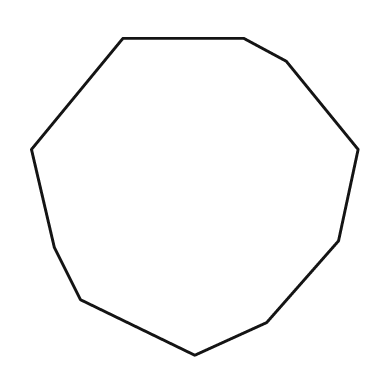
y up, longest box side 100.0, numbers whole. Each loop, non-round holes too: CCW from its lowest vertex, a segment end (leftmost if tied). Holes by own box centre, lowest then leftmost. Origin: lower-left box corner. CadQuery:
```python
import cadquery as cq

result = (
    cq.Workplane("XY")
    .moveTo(50.0, 0.0)
    .lineTo(72.0, 10.0)
    .lineTo(94.0, 35.0)
    .lineTo(100.0, 63.0)
    .lineTo(78.0, 90.0)
    .lineTo(65.0, 97.0)
    .lineTo(28.0, 97.0)
    .lineTo(0.0, 63.0)
    .lineTo(7.0, 33.0)
    .lineTo(15.0, 17.0)
    .close()
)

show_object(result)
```